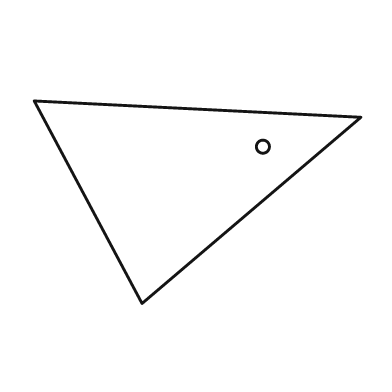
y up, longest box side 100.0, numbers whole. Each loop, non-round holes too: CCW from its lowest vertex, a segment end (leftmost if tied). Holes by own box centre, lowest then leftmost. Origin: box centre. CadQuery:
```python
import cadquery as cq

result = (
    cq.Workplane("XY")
    .moveTo(-17.0, -31.0)
    .lineTo(50.0, 26.0)
    .lineTo(-50.0, 31.0)
    .close()
    .moveTo(20.0, 17.0)
    .circle(2.0)
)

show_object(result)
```